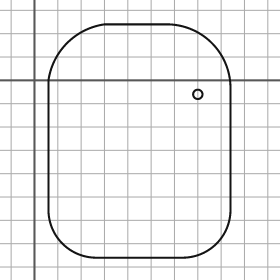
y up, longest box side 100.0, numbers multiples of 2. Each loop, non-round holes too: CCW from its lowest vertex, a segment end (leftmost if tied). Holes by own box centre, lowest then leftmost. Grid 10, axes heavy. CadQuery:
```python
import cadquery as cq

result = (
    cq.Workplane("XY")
    .moveTo(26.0, -76.0)
    .lineTo(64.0, -76.0)
    .threePointArc((78.0, -70.0), (84.0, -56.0))
    .lineTo(84.0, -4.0)
    .threePointArc((76.0, 16.0), (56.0, 24.0))
    .lineTo(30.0, 24.0)
    .threePointArc((14.0, 16.0), (6.0, 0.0))
    .lineTo(6.0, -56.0)
    .threePointArc((12.0, -70.0), (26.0, -76.0))
    .close()
    .moveTo(70.0, -6.0)
    .circle(2.0)
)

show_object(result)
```